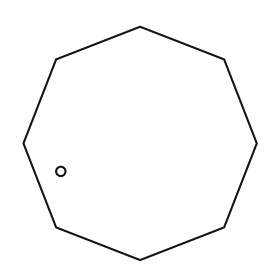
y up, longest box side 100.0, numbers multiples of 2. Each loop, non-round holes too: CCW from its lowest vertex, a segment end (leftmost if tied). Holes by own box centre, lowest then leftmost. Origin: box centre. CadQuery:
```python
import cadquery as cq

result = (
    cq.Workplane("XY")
    .moveTo(0.0, -50.0)
    .lineTo(36.0, -36.0)
    .lineTo(50.0, 0.0)
    .lineTo(36.0, 36.0)
    .lineTo(0.0, 50.0)
    .lineTo(-36.0, 36.0)
    .lineTo(-50.0, 0.0)
    .lineTo(-36.0, -36.0)
    .close()
    .moveTo(-34.0, -12.0)
    .circle(2.0)
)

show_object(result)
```